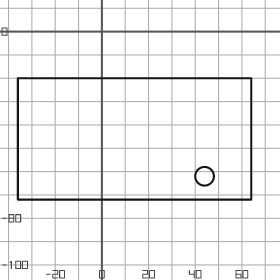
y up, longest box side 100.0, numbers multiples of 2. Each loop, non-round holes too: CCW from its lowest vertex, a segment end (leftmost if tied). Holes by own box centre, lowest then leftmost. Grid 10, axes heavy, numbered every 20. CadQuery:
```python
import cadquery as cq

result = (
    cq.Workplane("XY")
    .moveTo(-36.0, -72.0)
    .lineTo(64.0, -72.0)
    .lineTo(64.0, -20.0)
    .lineTo(-36.0, -20.0)
    .close()
    .moveTo(44.0, -62.0)
    .circle(4.0)
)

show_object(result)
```